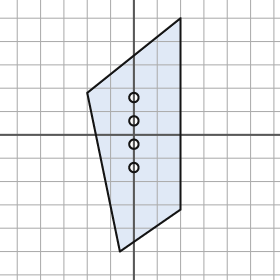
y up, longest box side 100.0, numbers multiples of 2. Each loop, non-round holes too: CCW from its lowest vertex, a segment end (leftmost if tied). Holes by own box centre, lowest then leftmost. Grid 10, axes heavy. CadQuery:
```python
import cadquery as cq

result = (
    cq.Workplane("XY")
    .moveTo(-6.0, -50.0)
    .lineTo(20.0, -32.0)
    .lineTo(20.0, 50.0)
    .lineTo(-20.0, 18.0)
    .close()
    .moveTo(0.0, -14.0)
    .circle(2.0)
    .moveTo(0.0, -4.0)
    .circle(2.0)
    .moveTo(0.0, 6.0)
    .circle(2.0)
    .moveTo(0.0, 16.0)
    .circle(2.0)
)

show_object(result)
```